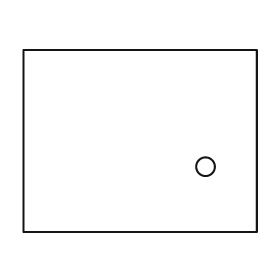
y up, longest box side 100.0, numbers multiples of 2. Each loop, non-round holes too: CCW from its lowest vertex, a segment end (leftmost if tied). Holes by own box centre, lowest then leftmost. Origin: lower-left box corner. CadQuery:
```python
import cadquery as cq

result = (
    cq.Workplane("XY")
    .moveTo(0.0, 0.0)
    .lineTo(100.0, 0.0)
    .lineTo(100.0, 78.0)
    .lineTo(0.0, 78.0)
    .close()
    .moveTo(78.0, 28.0)
    .circle(4.0)
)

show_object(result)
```